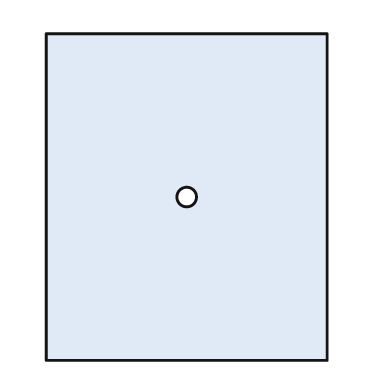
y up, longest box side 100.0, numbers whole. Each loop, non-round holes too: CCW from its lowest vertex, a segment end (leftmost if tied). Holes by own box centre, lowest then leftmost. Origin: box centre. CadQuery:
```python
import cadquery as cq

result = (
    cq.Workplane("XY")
    .moveTo(-43.0, -50.0)
    .lineTo(43.0, -50.0)
    .lineTo(43.0, 50.0)
    .lineTo(-43.0, 50.0)
    .close()
    .moveTo(0.0, 0.0)
    .circle(3.0)
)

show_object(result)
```